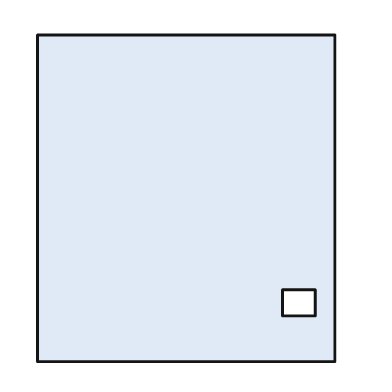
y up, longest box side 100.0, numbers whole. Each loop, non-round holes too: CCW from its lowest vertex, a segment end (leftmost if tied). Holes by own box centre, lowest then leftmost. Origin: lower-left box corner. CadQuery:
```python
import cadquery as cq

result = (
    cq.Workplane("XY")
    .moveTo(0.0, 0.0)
    .lineTo(91.0, 0.0)
    .lineTo(91.0, 100.0)
    .lineTo(0.0, 100.0)
    .close()
    .moveTo(75.0, 14.0)
    .lineTo(85.0, 14.0)
    .lineTo(85.0, 22.0)
    .lineTo(75.0, 22.0)
    .close()
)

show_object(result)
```